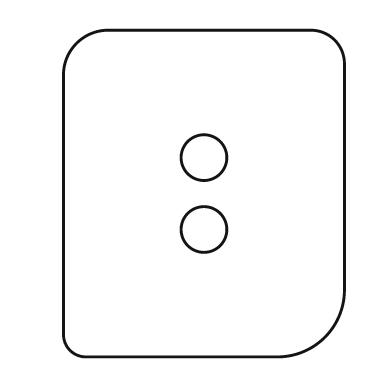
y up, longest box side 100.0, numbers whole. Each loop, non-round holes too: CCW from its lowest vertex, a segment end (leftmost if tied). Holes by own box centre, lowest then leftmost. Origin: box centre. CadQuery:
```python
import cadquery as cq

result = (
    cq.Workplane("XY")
    .moveTo(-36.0, -50.0)
    .lineTo(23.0, -50.0)
    .threePointArc((37.0, -44.0), (43.0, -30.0))
    .lineTo(43.0, 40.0)
    .threePointArc((40.0, 47.0), (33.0, 50.0))
    .lineTo(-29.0, 50.0)
    .threePointArc((-39.0, 46.0), (-43.0, 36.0))
    .lineTo(-43.0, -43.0)
    .threePointArc((-41.0, -48.0), (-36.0, -50.0))
    .close()
    .moveTo(0.0, -11.0)
    .circle(7.0)
    .moveTo(0.0, 11.0)
    .circle(7.0)
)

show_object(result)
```